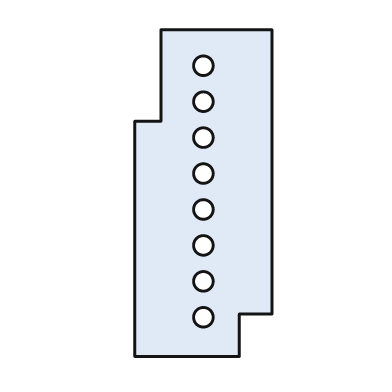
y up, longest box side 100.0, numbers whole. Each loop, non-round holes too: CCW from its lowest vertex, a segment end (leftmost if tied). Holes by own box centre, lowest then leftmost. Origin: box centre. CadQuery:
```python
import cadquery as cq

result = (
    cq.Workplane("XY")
    .moveTo(-21.0, -50.0)
    .lineTo(11.0, -50.0)
    .lineTo(11.0, -37.0)
    .lineTo(21.0, -37.0)
    .lineTo(21.0, 50.0)
    .lineTo(-13.0, 50.0)
    .lineTo(-13.0, 22.0)
    .lineTo(-21.0, 22.0)
    .close()
    .moveTo(0.0, -38.0)
    .circle(3.0)
    .moveTo(0.0, -27.0)
    .circle(3.0)
    .moveTo(0.0, -16.0)
    .circle(3.0)
    .moveTo(0.0, -5.0)
    .circle(3.0)
    .moveTo(0.0, 6.0)
    .circle(3.0)
    .moveTo(0.0, 17.0)
    .circle(3.0)
    .moveTo(0.0, 28.0)
    .circle(3.0)
    .moveTo(0.0, 39.0)
    .circle(3.0)
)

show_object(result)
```